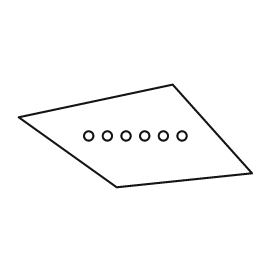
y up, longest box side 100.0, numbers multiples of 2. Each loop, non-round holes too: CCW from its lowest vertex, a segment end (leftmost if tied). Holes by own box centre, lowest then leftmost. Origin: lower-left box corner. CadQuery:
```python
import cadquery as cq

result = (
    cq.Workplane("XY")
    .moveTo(42.0, 0.0)
    .lineTo(100.0, 6.0)
    .lineTo(66.0, 44.0)
    .lineTo(0.0, 30.0)
    .close()
    .moveTo(30.0, 22.0)
    .circle(2.0)
    .moveTo(38.0, 22.0)
    .circle(2.0)
    .moveTo(46.0, 22.0)
    .circle(2.0)
    .moveTo(54.0, 22.0)
    .circle(2.0)
    .moveTo(62.0, 22.0)
    .circle(2.0)
    .moveTo(70.0, 22.0)
    .circle(2.0)
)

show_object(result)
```